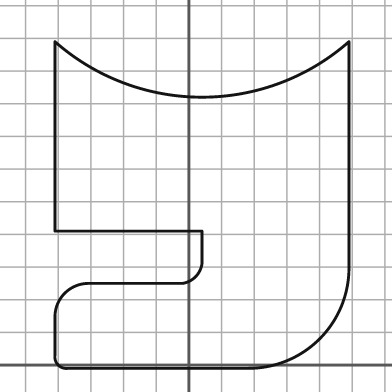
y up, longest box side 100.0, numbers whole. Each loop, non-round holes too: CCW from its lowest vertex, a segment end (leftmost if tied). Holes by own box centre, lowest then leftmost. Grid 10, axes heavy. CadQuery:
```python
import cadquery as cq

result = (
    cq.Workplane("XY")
    .moveTo(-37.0, -1.0)
    .lineTo(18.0, -1.0)
    .threePointArc((40.0, 8.0), (49.0, 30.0))
    .lineTo(49.0, 99.0)
    .threePointArc((4.0, 82.0), (-41.0, 99.0))
    .lineTo(-41.0, 41.0)
    .lineTo(4.0, 41.0)
    .lineTo(4.0, 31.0)
    .threePointArc((2.0, 27.0), (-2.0, 25.0))
    .lineTo(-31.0, 25.0)
    .threePointArc((-38.0, 22.0), (-41.0, 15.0))
    .lineTo(-41.0, 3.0)
    .threePointArc((-40.0, 0.0), (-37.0, -1.0))
    .close()
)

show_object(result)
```